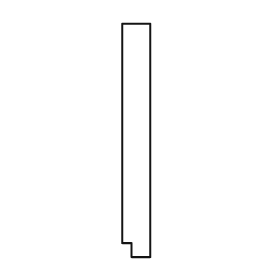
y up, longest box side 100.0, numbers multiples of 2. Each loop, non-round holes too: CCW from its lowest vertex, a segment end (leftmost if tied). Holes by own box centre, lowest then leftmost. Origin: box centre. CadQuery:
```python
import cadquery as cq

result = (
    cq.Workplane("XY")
    .moveTo(-2.0, -50.0)
    .lineTo(6.0, -50.0)
    .lineTo(6.0, 50.0)
    .lineTo(-6.0, 50.0)
    .lineTo(-6.0, -44.0)
    .lineTo(-2.0, -44.0)
    .close()
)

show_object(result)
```